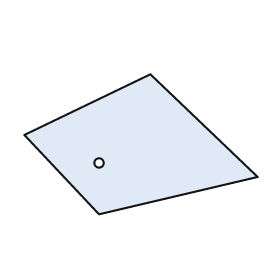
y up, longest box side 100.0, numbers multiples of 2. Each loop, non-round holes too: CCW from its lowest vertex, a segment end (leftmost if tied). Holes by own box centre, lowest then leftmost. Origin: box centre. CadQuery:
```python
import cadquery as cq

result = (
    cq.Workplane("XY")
    .moveTo(-18.0, -30.0)
    .lineTo(50.0, -14.0)
    .lineTo(4.0, 30.0)
    .lineTo(-50.0, 4.0)
    .close()
    .moveTo(-18.0, -8.0)
    .circle(2.0)
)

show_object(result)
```